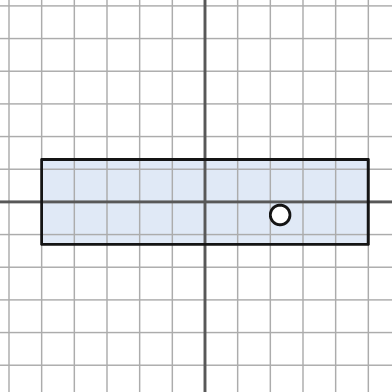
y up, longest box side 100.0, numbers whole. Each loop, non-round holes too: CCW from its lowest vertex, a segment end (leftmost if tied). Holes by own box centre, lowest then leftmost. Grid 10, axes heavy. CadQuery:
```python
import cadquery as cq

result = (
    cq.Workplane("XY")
    .moveTo(-50.0, -13.0)
    .lineTo(50.0, -13.0)
    .lineTo(50.0, 13.0)
    .lineTo(-50.0, 13.0)
    .close()
    .moveTo(23.0, -4.0)
    .circle(3.0)
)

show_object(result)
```